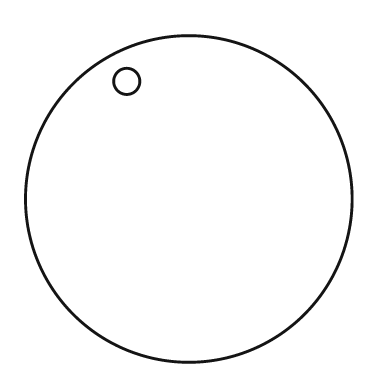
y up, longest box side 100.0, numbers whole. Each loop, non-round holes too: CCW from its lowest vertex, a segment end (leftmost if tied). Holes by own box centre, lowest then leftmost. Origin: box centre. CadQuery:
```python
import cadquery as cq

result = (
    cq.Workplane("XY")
    .moveTo(0.0, 0.0)
    .circle(50.0)
    .moveTo(-19.0, 36.0)
    .circle(4.0)
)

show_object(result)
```